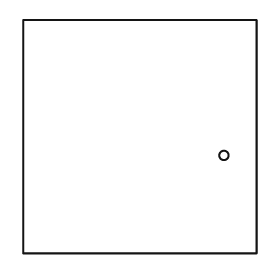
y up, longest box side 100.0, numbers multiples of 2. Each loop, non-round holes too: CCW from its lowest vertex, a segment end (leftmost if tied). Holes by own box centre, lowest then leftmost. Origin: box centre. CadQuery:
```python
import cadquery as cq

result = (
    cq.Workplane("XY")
    .moveTo(-50.0, -50.0)
    .lineTo(50.0, -50.0)
    .lineTo(50.0, 50.0)
    .lineTo(-50.0, 50.0)
    .close()
    .moveTo(36.0, -8.0)
    .circle(2.0)
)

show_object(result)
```